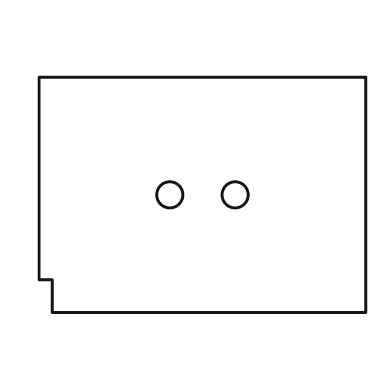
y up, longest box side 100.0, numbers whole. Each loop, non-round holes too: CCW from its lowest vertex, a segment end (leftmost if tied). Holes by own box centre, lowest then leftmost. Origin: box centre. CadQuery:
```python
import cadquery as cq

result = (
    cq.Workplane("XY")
    .moveTo(-46.0, -36.0)
    .lineTo(50.0, -36.0)
    .lineTo(50.0, 36.0)
    .lineTo(-50.0, 36.0)
    .lineTo(-50.0, -26.0)
    .lineTo(-46.0, -26.0)
    .close()
    .moveTo(-10.0, 0.0)
    .circle(4.0)
    .moveTo(10.0, 0.0)
    .circle(4.0)
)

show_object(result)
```